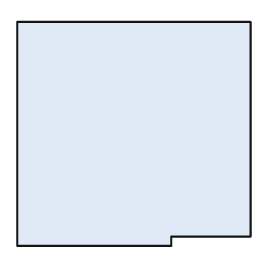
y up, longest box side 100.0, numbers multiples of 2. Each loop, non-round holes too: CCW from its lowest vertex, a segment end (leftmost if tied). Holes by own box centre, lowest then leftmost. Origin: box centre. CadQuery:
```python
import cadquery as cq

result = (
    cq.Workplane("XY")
    .moveTo(-50.0, -48.0)
    .lineTo(16.0, -48.0)
    .lineTo(16.0, -44.0)
    .lineTo(50.0, -44.0)
    .lineTo(50.0, 48.0)
    .lineTo(-50.0, 48.0)
    .close()
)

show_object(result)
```